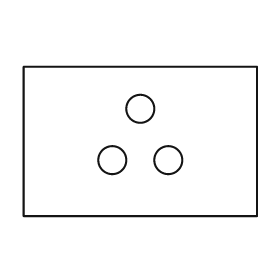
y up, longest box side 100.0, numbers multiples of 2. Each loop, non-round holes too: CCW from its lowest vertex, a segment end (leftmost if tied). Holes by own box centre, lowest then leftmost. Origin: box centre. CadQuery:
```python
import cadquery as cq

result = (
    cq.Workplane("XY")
    .moveTo(-50.0, -32.0)
    .lineTo(50.0, -32.0)
    .lineTo(50.0, 32.0)
    .lineTo(-50.0, 32.0)
    .close()
    .moveTo(-12.0, -8.0)
    .circle(6.0)
    .moveTo(12.0, -8.0)
    .circle(6.0)
    .moveTo(0.0, 14.0)
    .circle(6.0)
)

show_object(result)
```